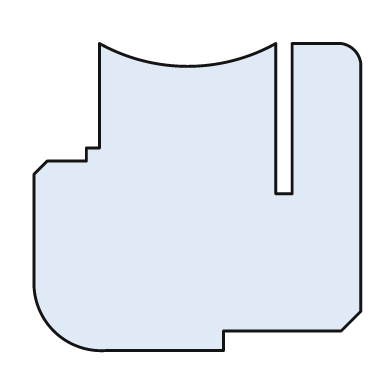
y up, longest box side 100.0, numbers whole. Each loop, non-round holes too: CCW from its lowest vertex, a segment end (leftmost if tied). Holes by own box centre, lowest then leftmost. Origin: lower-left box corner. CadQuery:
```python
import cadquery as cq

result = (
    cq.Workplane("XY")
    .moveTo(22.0, 0.0)
    .lineTo(58.0, 0.0)
    .lineTo(58.0, 6.0)
    .lineTo(94.0, 6.0)
    .lineTo(100.0, 12.0)
    .lineTo(100.0, 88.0)
    .threePointArc((98.0, 92.0), (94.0, 94.0))
    .lineTo(79.0, 94.0)
    .lineTo(79.0, 48.0)
    .lineTo(74.0, 48.0)
    .lineTo(74.0, 94.0)
    .threePointArc((47.0, 87.0), (20.0, 94.0))
    .lineTo(20.0, 62.0)
    .lineTo(16.0, 62.0)
    .lineTo(16.0, 58.0)
    .lineTo(4.0, 58.0)
    .lineTo(0.0, 54.0)
    .lineTo(0.0, 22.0)
    .threePointArc((6.0, 6.0), (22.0, 0.0))
    .close()
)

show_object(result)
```